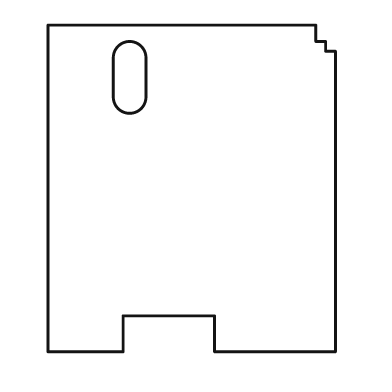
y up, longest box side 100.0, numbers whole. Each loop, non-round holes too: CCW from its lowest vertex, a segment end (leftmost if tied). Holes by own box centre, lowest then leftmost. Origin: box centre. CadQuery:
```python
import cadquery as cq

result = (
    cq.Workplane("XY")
    .moveTo(-44.0, -50.0)
    .lineTo(-21.0, -50.0)
    .lineTo(-21.0, -39.0)
    .lineTo(7.0, -39.0)
    .lineTo(7.0, -50.0)
    .lineTo(44.0, -50.0)
    .lineTo(44.0, 42.0)
    .lineTo(41.0, 42.0)
    .lineTo(41.0, 45.0)
    .lineTo(38.0, 45.0)
    .lineTo(38.0, 50.0)
    .lineTo(-44.0, 50.0)
    .close()
    .moveTo(-24.0, 28.0)
    .threePointArc((-19.0, 23.0), (-14.0, 28.0))
    .lineTo(-14.0, 40.0)
    .threePointArc((-19.0, 45.0), (-24.0, 40.0))
    .close()
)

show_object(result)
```